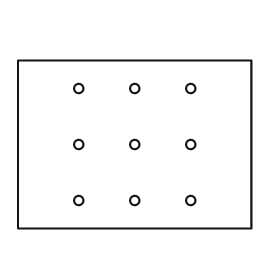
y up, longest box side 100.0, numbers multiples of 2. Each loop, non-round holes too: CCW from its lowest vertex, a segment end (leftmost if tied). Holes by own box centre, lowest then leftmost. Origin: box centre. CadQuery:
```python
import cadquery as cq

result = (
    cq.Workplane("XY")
    .moveTo(-50.0, -36.0)
    .lineTo(50.0, -36.0)
    .lineTo(50.0, 36.0)
    .lineTo(-50.0, 36.0)
    .close()
    .moveTo(-24.0, -24.0)
    .circle(2.0)
    .moveTo(0.0, -24.0)
    .circle(2.0)
    .moveTo(24.0, -24.0)
    .circle(2.0)
    .moveTo(-24.0, 0.0)
    .circle(2.0)
    .moveTo(0.0, 0.0)
    .circle(2.0)
    .moveTo(24.0, 0.0)
    .circle(2.0)
    .moveTo(-24.0, 24.0)
    .circle(2.0)
    .moveTo(0.0, 24.0)
    .circle(2.0)
    .moveTo(24.0, 24.0)
    .circle(2.0)
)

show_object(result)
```